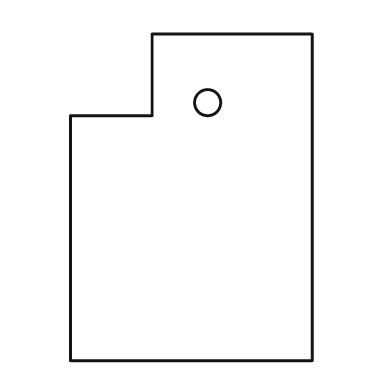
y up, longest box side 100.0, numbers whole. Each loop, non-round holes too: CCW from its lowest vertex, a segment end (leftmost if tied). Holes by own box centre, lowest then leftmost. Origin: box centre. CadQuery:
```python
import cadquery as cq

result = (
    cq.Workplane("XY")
    .moveTo(-37.0, -50.0)
    .lineTo(37.0, -50.0)
    .lineTo(37.0, 50.0)
    .lineTo(-12.0, 50.0)
    .lineTo(-12.0, 25.0)
    .lineTo(-37.0, 25.0)
    .close()
    .moveTo(5.0, 29.0)
    .circle(4.0)
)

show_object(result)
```